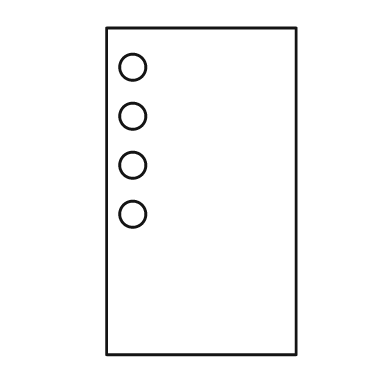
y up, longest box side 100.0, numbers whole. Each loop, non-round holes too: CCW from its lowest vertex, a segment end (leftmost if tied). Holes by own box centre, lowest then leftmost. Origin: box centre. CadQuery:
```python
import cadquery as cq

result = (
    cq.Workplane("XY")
    .moveTo(-29.0, -50.0)
    .lineTo(29.0, -50.0)
    .lineTo(29.0, 50.0)
    .lineTo(-29.0, 50.0)
    .close()
    .moveTo(-21.0, -7.0)
    .circle(4.0)
    .moveTo(-21.0, 8.0)
    .circle(4.0)
    .moveTo(-21.0, 23.0)
    .circle(4.0)
    .moveTo(-21.0, 38.0)
    .circle(4.0)
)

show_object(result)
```